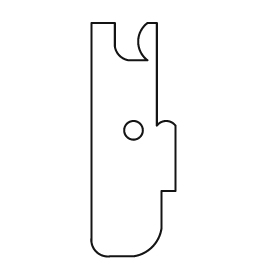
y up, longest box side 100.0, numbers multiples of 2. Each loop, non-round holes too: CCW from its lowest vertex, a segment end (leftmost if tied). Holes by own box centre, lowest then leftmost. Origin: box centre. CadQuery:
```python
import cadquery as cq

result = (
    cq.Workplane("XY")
    .moveTo(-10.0, -50.0)
    .lineTo(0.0, -50.0)
    .threePointArc((8.0, -46.0), (12.0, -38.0))
    .lineTo(12.0, -22.0)
    .lineTo(18.0, -22.0)
    .lineTo(18.0, 6.0)
    .threePointArc((14.0, 8.0), (10.0, 6.0))
    .lineTo(10.0, 50.0)
    .lineTo(6.0, 50.0)
    .threePointArc((2.0, 42.0), (6.0, 34.0))
    .lineTo(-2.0, 34.0)
    .threePointArc((-6.0, 36.0), (-8.0, 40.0))
    .lineTo(-8.0, 50.0)
    .lineTo(-18.0, 50.0)
    .lineTo(-18.0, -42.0)
    .threePointArc((-16.0, -48.0), (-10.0, -50.0))
    .close()
    .moveTo(0.0, 4.0)
    .circle(4.0)
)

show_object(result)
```